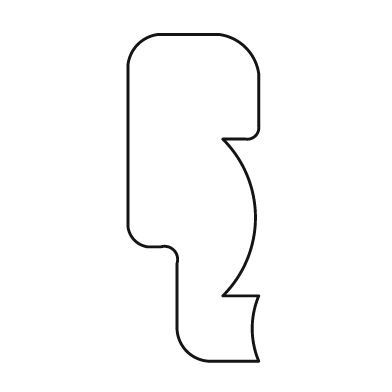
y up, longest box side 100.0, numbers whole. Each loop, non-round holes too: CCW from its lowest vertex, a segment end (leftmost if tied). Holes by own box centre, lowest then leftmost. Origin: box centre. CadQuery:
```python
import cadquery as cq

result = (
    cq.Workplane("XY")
    .moveTo(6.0, -50.0)
    .lineTo(20.0, -50.0)
    .threePointArc((18.0, -40.0), (20.0, -30.0))
    .lineTo(9.0, -30.0)
    .threePointArc((19.0, -6.0), (9.0, 18.0))
    .lineTo(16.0, 18.0)
    .threePointArc((19.0, 19.0), (20.0, 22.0))
    .lineTo(20.0, 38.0)
    .threePointArc((16.0, 46.0), (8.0, 50.0))
    .lineTo(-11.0, 50.0)
    .threePointArc((-17.0, 47.0), (-20.0, 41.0))
    .lineTo(-20.0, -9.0)
    .threePointArc((-18.0, -13.0), (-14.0, -15.0))
    .lineTo(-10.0, -15.0)
    .threePointArc((-6.0, -16.0), (-5.0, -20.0))
    .lineTo(-5.0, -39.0)
    .threePointArc((-2.0, -47.0), (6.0, -50.0))
    .close()
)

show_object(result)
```